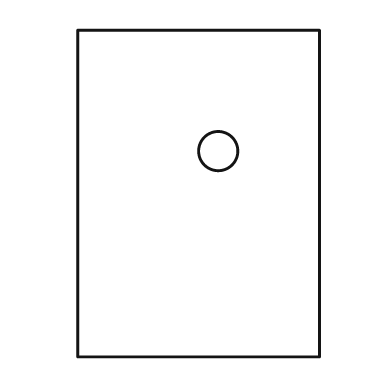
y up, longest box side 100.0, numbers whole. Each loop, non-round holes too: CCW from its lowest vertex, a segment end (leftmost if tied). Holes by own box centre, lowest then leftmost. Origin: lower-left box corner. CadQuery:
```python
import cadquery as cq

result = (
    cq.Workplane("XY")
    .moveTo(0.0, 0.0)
    .lineTo(74.0, 0.0)
    .lineTo(74.0, 100.0)
    .lineTo(0.0, 100.0)
    .close()
    .moveTo(43.0, 63.0)
    .circle(6.0)
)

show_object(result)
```